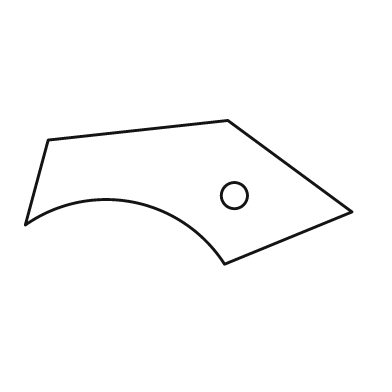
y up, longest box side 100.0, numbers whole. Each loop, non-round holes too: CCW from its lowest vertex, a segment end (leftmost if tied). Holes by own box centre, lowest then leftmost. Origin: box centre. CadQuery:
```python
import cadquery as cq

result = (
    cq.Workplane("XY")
    .moveTo(11.0, -22.0)
    .lineTo(50.0, -6.0)
    .lineTo(12.0, 22.0)
    .lineTo(-43.0, 16.0)
    .lineTo(-50.0, -10.0)
    .threePointArc((-17.0, -3.0), (11.0, -22.0))
    .close()
    .moveTo(14.0, -1.0)
    .circle(4.0)
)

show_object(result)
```